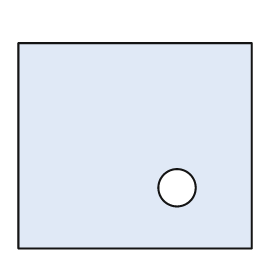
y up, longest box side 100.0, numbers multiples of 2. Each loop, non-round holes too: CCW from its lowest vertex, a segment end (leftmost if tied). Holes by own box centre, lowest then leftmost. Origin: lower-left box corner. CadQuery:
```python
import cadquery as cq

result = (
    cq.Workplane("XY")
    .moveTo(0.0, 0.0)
    .lineTo(100.0, 0.0)
    .lineTo(100.0, 88.0)
    .lineTo(0.0, 88.0)
    .close()
    .moveTo(68.0, 26.0)
    .circle(8.0)
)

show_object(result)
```